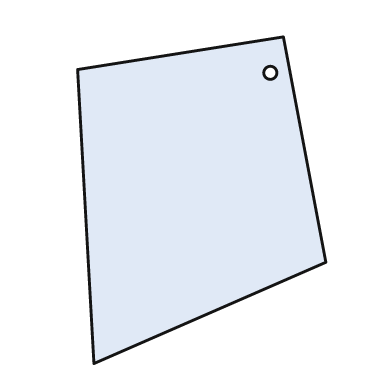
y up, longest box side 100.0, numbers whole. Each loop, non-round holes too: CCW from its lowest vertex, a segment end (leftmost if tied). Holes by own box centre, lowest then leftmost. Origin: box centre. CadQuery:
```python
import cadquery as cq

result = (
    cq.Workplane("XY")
    .moveTo(-33.0, -50.0)
    .lineTo(38.0, -19.0)
    .lineTo(25.0, 50.0)
    .lineTo(-38.0, 40.0)
    .close()
    .moveTo(21.0, 39.0)
    .circle(2.0)
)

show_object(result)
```